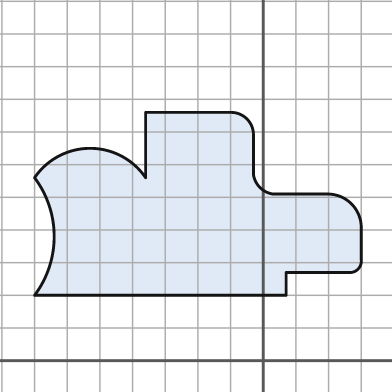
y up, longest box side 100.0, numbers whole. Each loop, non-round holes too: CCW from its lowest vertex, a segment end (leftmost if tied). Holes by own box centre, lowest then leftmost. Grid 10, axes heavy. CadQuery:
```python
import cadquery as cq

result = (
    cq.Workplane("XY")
    .moveTo(-70.0, 20.0)
    .lineTo(7.0, 20.0)
    .lineTo(7.0, 27.0)
    .lineTo(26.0, 27.0)
    .threePointArc((29.0, 28.0), (30.0, 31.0))
    .lineTo(30.0, 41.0)
    .threePointArc((27.0, 48.0), (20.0, 51.0))
    .lineTo(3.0, 51.0)
    .threePointArc((-1.0, 53.0), (-3.0, 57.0))
    .lineTo(-3.0, 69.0)
    .threePointArc((-5.0, 74.0), (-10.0, 76.0))
    .lineTo(-36.0, 76.0)
    .lineTo(-36.0, 56.0)
    .threePointArc((-53.0, 65.0), (-70.0, 56.0))
    .threePointArc((-64.0, 38.0), (-70.0, 20.0))
    .close()
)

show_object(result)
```